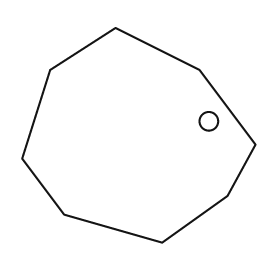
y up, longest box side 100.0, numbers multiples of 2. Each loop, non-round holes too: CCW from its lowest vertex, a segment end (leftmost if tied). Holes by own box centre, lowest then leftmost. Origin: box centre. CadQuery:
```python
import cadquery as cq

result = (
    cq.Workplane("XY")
    .moveTo(10.0, -46.0)
    .lineTo(38.0, -26.0)
    .lineTo(50.0, -4.0)
    .lineTo(26.0, 28.0)
    .lineTo(-10.0, 46.0)
    .lineTo(-38.0, 28.0)
    .lineTo(-50.0, -10.0)
    .lineTo(-32.0, -34.0)
    .close()
    .moveTo(30.0, 6.0)
    .circle(4.0)
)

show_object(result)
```